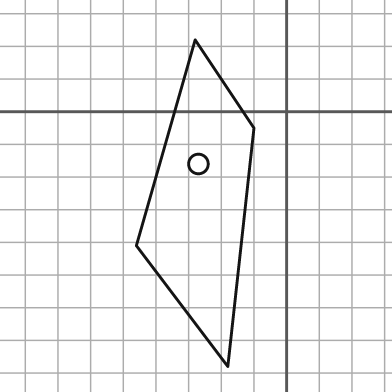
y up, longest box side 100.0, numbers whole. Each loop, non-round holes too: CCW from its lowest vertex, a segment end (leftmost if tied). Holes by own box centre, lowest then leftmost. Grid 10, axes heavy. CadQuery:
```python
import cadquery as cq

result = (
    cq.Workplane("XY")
    .moveTo(-18.0, -78.0)
    .lineTo(-10.0, -5.0)
    .lineTo(-28.0, 22.0)
    .lineTo(-46.0, -41.0)
    .close()
    .moveTo(-27.0, -16.0)
    .circle(3.0)
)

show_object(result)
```